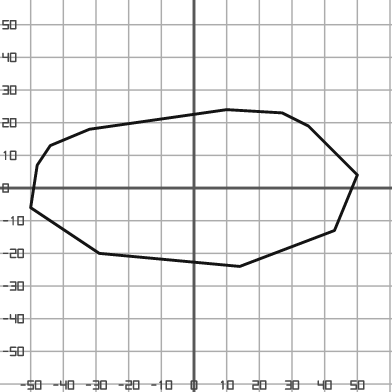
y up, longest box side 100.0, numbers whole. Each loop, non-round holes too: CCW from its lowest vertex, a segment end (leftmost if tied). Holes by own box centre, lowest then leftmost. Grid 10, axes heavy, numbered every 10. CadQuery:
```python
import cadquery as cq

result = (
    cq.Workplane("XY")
    .moveTo(14.0, -24.0)
    .lineTo(43.0, -13.0)
    .lineTo(50.0, 4.0)
    .lineTo(35.0, 19.0)
    .lineTo(27.0, 23.0)
    .lineTo(10.0, 24.0)
    .lineTo(-32.0, 18.0)
    .lineTo(-44.0, 13.0)
    .lineTo(-48.0, 7.0)
    .lineTo(-50.0, -6.0)
    .lineTo(-29.0, -20.0)
    .close()
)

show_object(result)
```